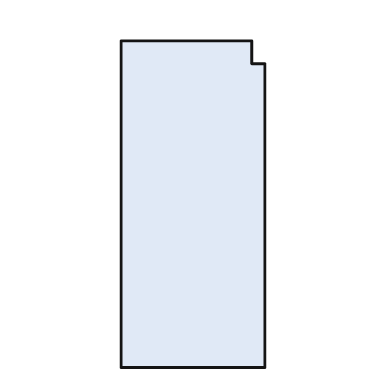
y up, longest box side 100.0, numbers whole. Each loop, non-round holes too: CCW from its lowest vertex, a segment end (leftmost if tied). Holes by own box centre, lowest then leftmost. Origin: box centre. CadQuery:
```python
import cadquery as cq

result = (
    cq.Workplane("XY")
    .moveTo(-22.0, -50.0)
    .lineTo(22.0, -50.0)
    .lineTo(22.0, 43.0)
    .lineTo(18.0, 43.0)
    .lineTo(18.0, 50.0)
    .lineTo(-22.0, 50.0)
    .close()
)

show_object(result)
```